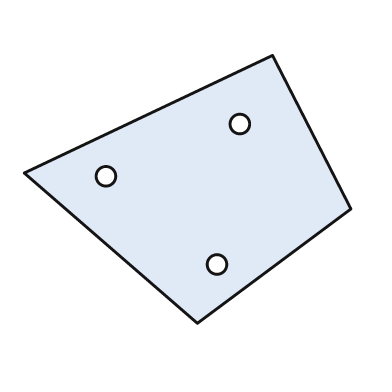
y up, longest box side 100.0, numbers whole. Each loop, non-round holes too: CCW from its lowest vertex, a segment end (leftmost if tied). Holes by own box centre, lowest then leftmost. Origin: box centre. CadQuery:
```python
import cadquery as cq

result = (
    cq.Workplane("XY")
    .moveTo(3.0, -41.0)
    .lineTo(50.0, -6.0)
    .lineTo(26.0, 41.0)
    .lineTo(-50.0, 5.0)
    .close()
    .moveTo(9.0, -23.0)
    .circle(3.0)
    .moveTo(-25.0, 4.0)
    .circle(3.0)
    .moveTo(16.0, 20.0)
    .circle(3.0)
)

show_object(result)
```